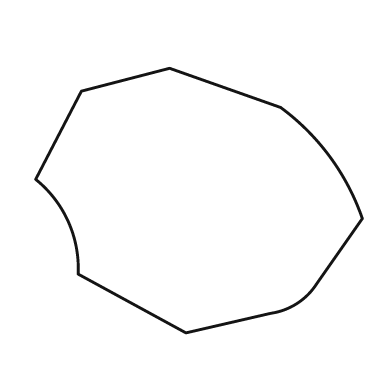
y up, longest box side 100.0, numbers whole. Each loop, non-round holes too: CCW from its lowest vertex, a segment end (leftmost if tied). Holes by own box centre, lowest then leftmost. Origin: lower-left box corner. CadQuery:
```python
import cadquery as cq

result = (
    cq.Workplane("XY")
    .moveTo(46.0, 0.0)
    .lineTo(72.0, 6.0)
    .threePointArc((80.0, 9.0), (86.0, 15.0))
    .lineTo(100.0, 35.0)
    .threePointArc((90.0, 54.0), (75.0, 69.0))
    .lineTo(41.0, 81.0)
    .lineTo(14.0, 74.0)
    .lineTo(0.0, 47.0)
    .threePointArc((10.0, 34.0), (13.0, 18.0))
    .close()
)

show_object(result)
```